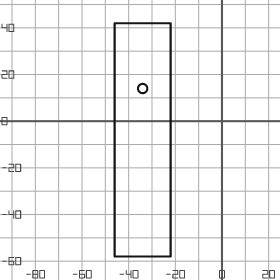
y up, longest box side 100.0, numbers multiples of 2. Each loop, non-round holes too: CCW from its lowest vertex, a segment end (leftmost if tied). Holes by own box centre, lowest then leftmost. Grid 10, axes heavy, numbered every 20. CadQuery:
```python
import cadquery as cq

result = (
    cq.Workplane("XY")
    .moveTo(-46.0, -58.0)
    .lineTo(-22.0, -58.0)
    .lineTo(-22.0, 42.0)
    .lineTo(-46.0, 42.0)
    .close()
    .moveTo(-34.0, 14.0)
    .circle(2.0)
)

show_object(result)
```